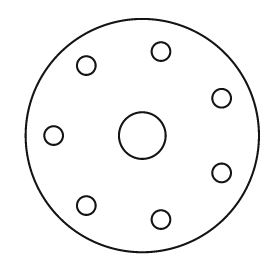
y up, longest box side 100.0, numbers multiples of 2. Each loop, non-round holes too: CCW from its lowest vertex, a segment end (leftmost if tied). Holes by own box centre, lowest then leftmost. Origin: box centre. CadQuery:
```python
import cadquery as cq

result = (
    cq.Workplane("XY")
    .moveTo(0.0, 0.0)
    .circle(50.0)
    .moveTo(8.0, -36.0)
    .circle(4.0)
    .moveTo(-24.0, -30.0)
    .circle(4.0)
    .moveTo(34.0, -16.0)
    .circle(4.0)
    .moveTo(-38.0, 0.0)
    .circle(4.0)
    .moveTo(0.0, 0.0)
    .circle(10.0)
    .moveTo(34.0, 16.0)
    .circle(4.0)
    .moveTo(-24.0, 30.0)
    .circle(4.0)
    .moveTo(8.0, 36.0)
    .circle(4.0)
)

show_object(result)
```